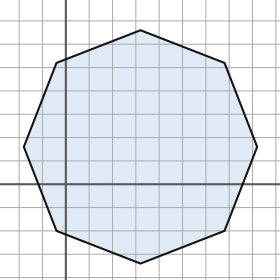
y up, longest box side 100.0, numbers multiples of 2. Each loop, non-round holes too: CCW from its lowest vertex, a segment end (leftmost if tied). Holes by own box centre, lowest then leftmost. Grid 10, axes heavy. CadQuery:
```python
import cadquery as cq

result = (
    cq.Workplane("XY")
    .moveTo(32.0, -34.0)
    .lineTo(68.0, -20.0)
    .lineTo(82.0, 16.0)
    .lineTo(68.0, 52.0)
    .lineTo(32.0, 66.0)
    .lineTo(-4.0, 52.0)
    .lineTo(-18.0, 16.0)
    .lineTo(-4.0, -20.0)
    .close()
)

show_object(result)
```